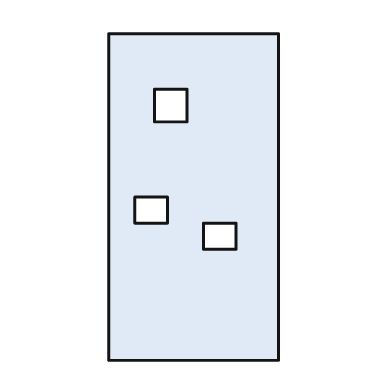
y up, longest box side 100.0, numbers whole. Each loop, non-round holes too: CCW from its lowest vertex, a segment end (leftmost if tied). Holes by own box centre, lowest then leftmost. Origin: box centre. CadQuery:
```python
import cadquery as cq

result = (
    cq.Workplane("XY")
    .moveTo(-26.0, -50.0)
    .lineTo(26.0, -50.0)
    .lineTo(26.0, 50.0)
    .lineTo(-26.0, 50.0)
    .close()
    .moveTo(3.0, -16.0)
    .lineTo(13.0, -16.0)
    .lineTo(13.0, -8.0)
    .lineTo(3.0, -8.0)
    .close()
    .moveTo(-18.0, -8.0)
    .lineTo(-8.0, -8.0)
    .lineTo(-8.0, 0.0)
    .lineTo(-18.0, 0.0)
    .close()
    .moveTo(-12.0, 23.0)
    .lineTo(-2.0, 23.0)
    .lineTo(-2.0, 33.0)
    .lineTo(-12.0, 33.0)
    .close()
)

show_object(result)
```